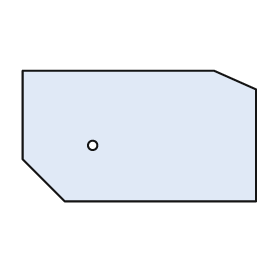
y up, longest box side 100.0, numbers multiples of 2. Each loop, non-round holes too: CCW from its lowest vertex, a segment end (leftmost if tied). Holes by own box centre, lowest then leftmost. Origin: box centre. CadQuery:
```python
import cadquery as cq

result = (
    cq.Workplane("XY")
    .moveTo(-32.0, -28.0)
    .lineTo(50.0, -28.0)
    .lineTo(50.0, 20.0)
    .lineTo(32.0, 28.0)
    .lineTo(-50.0, 28.0)
    .lineTo(-50.0, -10.0)
    .close()
    .moveTo(-20.0, -4.0)
    .circle(2.0)
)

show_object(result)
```